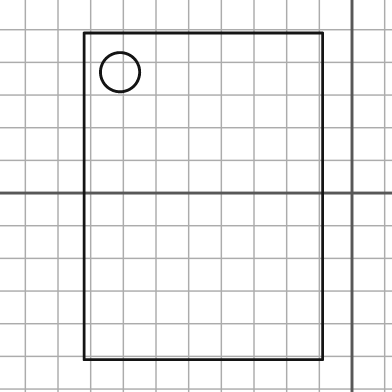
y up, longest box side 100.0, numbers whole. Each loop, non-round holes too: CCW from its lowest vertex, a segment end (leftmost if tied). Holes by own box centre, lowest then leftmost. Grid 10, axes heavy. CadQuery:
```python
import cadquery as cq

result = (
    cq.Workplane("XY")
    .moveTo(-82.0, -51.0)
    .lineTo(-9.0, -51.0)
    .lineTo(-9.0, 49.0)
    .lineTo(-82.0, 49.0)
    .close()
    .moveTo(-71.0, 37.0)
    .circle(6.0)
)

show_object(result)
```